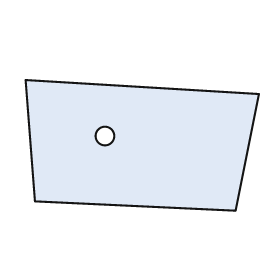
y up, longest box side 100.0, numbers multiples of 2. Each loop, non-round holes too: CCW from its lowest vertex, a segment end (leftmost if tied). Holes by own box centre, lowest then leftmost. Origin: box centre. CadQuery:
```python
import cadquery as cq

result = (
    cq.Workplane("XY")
    .moveTo(40.0, -28.0)
    .lineTo(50.0, 22.0)
    .lineTo(-50.0, 28.0)
    .lineTo(-46.0, -24.0)
    .close()
    .moveTo(-16.0, 4.0)
    .circle(4.0)
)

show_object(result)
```